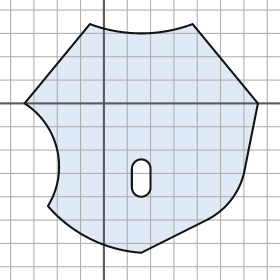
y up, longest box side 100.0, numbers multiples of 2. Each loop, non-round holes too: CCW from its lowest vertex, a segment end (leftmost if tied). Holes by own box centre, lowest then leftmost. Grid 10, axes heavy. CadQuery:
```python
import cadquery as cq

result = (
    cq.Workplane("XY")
    .moveTo(16.0, -64.0)
    .lineTo(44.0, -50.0)
    .threePointArc((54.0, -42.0), (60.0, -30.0))
    .lineTo(66.0, 0.0)
    .lineTo(38.0, 34.0)
    .threePointArc((16.0, 30.0), (-6.0, 34.0))
    .lineTo(-34.0, 0.0)
    .threePointArc((-20.0, -20.0), (-24.0, -44.0))
    .threePointArc((-6.0, -58.0), (16.0, -64.0))
    .close()
    .moveTo(12.0, -36.0)
    .threePointArc((16.0, -40.0), (20.0, -36.0))
    .lineTo(20.0, -28.0)
    .threePointArc((16.0, -24.0), (12.0, -28.0))
    .close()
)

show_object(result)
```